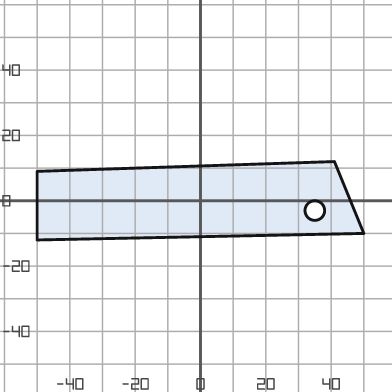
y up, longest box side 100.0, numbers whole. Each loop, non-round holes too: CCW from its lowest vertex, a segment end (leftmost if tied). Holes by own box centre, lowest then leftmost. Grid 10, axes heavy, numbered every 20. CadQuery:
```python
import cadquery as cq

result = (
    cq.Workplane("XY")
    .moveTo(-50.0, -12.0)
    .lineTo(50.0, -10.0)
    .lineTo(41.0, 12.0)
    .lineTo(-50.0, 9.0)
    .close()
    .moveTo(35.0, -3.0)
    .circle(3.0)
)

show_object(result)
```